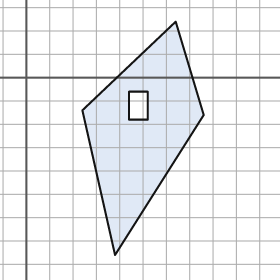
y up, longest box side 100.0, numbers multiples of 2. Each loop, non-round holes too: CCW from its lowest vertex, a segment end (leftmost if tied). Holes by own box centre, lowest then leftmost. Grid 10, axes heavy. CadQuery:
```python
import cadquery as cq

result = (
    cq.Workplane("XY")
    .moveTo(38.0, -76.0)
    .lineTo(76.0, -16.0)
    .lineTo(64.0, 24.0)
    .lineTo(24.0, -14.0)
    .close()
    .moveTo(44.0, -18.0)
    .lineTo(52.0, -18.0)
    .lineTo(52.0, -6.0)
    .lineTo(44.0, -6.0)
    .close()
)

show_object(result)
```